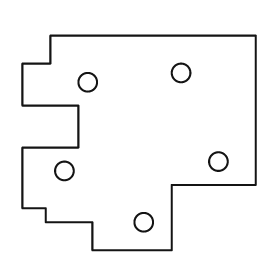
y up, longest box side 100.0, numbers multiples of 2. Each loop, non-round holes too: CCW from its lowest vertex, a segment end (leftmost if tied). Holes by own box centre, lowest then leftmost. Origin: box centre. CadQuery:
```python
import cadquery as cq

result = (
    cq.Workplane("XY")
    .moveTo(-20.0, -46.0)
    .lineTo(14.0, -46.0)
    .lineTo(14.0, -18.0)
    .lineTo(50.0, -18.0)
    .lineTo(50.0, 46.0)
    .lineTo(-38.0, 46.0)
    .lineTo(-38.0, 34.0)
    .lineTo(-50.0, 34.0)
    .lineTo(-50.0, 16.0)
    .lineTo(-26.0, 16.0)
    .lineTo(-26.0, -2.0)
    .lineTo(-50.0, -2.0)
    .lineTo(-50.0, -28.0)
    .lineTo(-40.0, -28.0)
    .lineTo(-40.0, -34.0)
    .lineTo(-20.0, -34.0)
    .close()
    .moveTo(2.0, -34.0)
    .circle(4.0)
    .moveTo(-32.0, -12.0)
    .circle(4.0)
    .moveTo(34.0, -8.0)
    .circle(4.0)
    .moveTo(-22.0, 26.0)
    .circle(4.0)
    .moveTo(18.0, 30.0)
    .circle(4.0)
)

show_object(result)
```